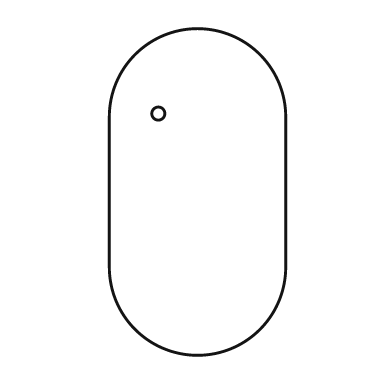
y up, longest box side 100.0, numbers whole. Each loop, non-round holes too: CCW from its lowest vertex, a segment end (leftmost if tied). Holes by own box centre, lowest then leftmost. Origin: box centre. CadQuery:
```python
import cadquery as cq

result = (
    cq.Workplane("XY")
    .moveTo(-27.0, -23.0)
    .threePointArc((0.0, -50.0), (27.0, -23.0))
    .lineTo(27.0, 23.0)
    .threePointArc((0.0, 50.0), (-27.0, 23.0))
    .close()
    .moveTo(-12.0, 24.0)
    .circle(2.0)
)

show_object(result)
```